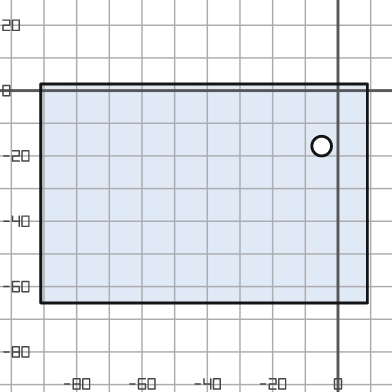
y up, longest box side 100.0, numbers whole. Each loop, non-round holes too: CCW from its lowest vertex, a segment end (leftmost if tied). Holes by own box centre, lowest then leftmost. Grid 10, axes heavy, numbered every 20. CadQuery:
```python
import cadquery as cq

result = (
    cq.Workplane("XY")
    .moveTo(-91.0, -65.0)
    .lineTo(9.0, -65.0)
    .lineTo(9.0, 2.0)
    .lineTo(-91.0, 2.0)
    .close()
    .moveTo(-5.0, -17.0)
    .circle(3.0)
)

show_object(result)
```